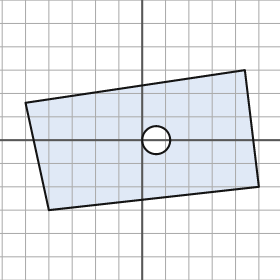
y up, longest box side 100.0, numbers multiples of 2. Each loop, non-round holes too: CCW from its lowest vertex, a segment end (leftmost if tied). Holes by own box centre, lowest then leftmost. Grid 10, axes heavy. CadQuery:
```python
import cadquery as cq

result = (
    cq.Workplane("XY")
    .moveTo(-40.0, -30.0)
    .lineTo(50.0, -20.0)
    .lineTo(44.0, 30.0)
    .lineTo(-50.0, 16.0)
    .close()
    .moveTo(6.0, 0.0)
    .circle(6.0)
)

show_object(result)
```